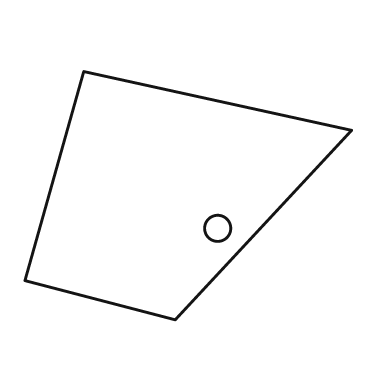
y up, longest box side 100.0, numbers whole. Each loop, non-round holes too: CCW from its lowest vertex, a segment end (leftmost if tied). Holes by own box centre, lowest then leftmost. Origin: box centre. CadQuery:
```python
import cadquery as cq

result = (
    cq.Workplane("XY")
    .moveTo(-4.0, -38.0)
    .lineTo(50.0, 20.0)
    .lineTo(-32.0, 38.0)
    .lineTo(-50.0, -26.0)
    .close()
    .moveTo(9.0, -10.0)
    .circle(4.0)
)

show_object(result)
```